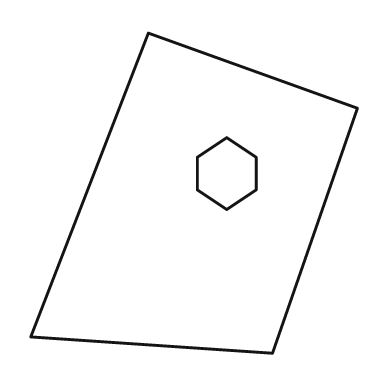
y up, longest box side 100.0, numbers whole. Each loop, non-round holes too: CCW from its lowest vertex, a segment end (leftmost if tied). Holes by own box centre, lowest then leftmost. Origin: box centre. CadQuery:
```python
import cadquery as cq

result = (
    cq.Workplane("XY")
    .moveTo(24.0, -49.0)
    .lineTo(50.0, 26.0)
    .lineTo(-14.0, 49.0)
    .lineTo(-50.0, -44.0)
    .close()
    .moveTo(10.0, -5.0)
    .lineTo(19.0, 1.0)
    .lineTo(19.0, 11.0)
    .lineTo(10.0, 17.0)
    .lineTo(1.0, 11.0)
    .lineTo(1.0, 1.0)
    .close()
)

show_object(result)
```